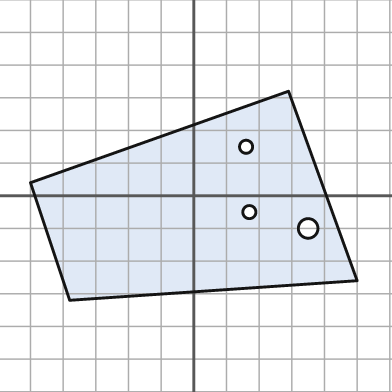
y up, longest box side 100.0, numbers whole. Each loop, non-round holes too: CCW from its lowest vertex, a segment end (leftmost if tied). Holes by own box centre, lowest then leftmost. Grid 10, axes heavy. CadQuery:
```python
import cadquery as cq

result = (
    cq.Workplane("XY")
    .moveTo(-38.0, -32.0)
    .lineTo(50.0, -26.0)
    .lineTo(29.0, 32.0)
    .lineTo(-50.0, 4.0)
    .close()
    .moveTo(35.0, -10.0)
    .circle(3.0)
    .moveTo(17.0, -5.0)
    .circle(2.0)
    .moveTo(16.0, 15.0)
    .circle(2.0)
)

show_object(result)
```